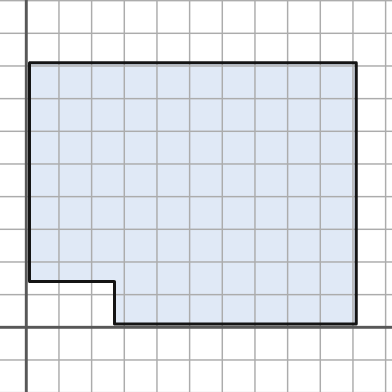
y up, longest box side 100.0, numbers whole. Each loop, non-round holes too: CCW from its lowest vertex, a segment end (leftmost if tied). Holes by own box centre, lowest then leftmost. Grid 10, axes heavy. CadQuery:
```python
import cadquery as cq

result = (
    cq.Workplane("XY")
    .moveTo(27.0, 1.0)
    .lineTo(101.0, 1.0)
    .lineTo(101.0, 81.0)
    .lineTo(1.0, 81.0)
    .lineTo(1.0, 14.0)
    .lineTo(27.0, 14.0)
    .close()
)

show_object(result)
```